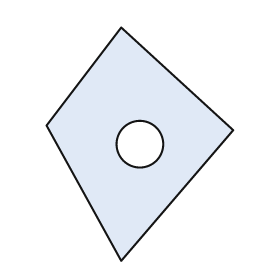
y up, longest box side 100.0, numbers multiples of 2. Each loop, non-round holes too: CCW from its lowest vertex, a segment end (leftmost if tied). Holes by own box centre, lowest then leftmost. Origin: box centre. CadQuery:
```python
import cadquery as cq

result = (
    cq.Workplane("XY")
    .moveTo(-8.0, -50.0)
    .lineTo(40.0, 6.0)
    .lineTo(-8.0, 50.0)
    .lineTo(-40.0, 8.0)
    .close()
    .moveTo(0.0, 0.0)
    .circle(10.0)
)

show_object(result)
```